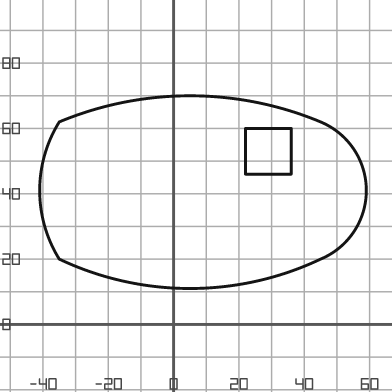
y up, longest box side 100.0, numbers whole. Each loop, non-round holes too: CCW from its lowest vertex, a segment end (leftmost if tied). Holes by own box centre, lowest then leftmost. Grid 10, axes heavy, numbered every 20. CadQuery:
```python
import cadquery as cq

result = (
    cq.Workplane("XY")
    .moveTo(-35.0, 20.0)
    .threePointArc((5.0, 11.0), (45.0, 20.0))
    .threePointArc((59.0, 41.0), (45.0, 62.0))
    .threePointArc((5.0, 70.0), (-35.0, 62.0))
    .threePointArc((-41.0, 41.0), (-35.0, 20.0))
    .close()
    .moveTo(22.0, 46.0)
    .lineTo(36.0, 46.0)
    .lineTo(36.0, 60.0)
    .lineTo(22.0, 60.0)
    .close()
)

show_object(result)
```